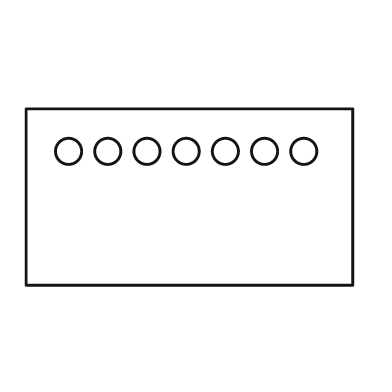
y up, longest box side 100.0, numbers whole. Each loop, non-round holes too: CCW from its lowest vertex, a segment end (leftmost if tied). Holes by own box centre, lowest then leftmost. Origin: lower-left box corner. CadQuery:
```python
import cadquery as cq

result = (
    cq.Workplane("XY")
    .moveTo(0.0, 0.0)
    .lineTo(100.0, 0.0)
    .lineTo(100.0, 54.0)
    .lineTo(0.0, 54.0)
    .close()
    .moveTo(13.0, 41.0)
    .circle(4.0)
    .moveTo(25.0, 41.0)
    .circle(4.0)
    .moveTo(37.0, 41.0)
    .circle(4.0)
    .moveTo(49.0, 41.0)
    .circle(4.0)
    .moveTo(61.0, 41.0)
    .circle(4.0)
    .moveTo(73.0, 41.0)
    .circle(4.0)
    .moveTo(85.0, 41.0)
    .circle(4.0)
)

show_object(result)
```